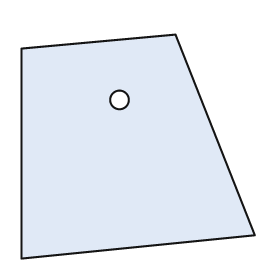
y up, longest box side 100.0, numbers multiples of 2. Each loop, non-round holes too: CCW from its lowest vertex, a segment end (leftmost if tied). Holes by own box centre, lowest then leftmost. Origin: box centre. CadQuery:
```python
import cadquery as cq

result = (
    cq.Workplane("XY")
    .moveTo(-50.0, -48.0)
    .lineTo(50.0, -38.0)
    .lineTo(16.0, 48.0)
    .lineTo(-50.0, 42.0)
    .close()
    .moveTo(-8.0, 20.0)
    .circle(4.0)
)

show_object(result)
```